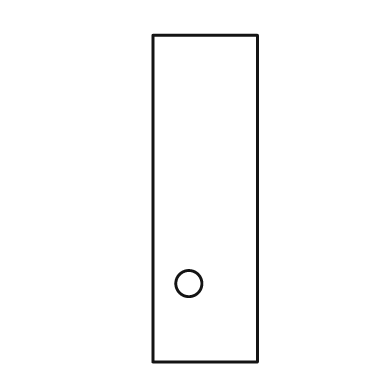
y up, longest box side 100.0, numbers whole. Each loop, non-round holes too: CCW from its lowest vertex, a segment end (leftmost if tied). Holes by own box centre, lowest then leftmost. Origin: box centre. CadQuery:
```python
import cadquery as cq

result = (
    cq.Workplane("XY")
    .moveTo(-16.0, -50.0)
    .lineTo(16.0, -50.0)
    .lineTo(16.0, 50.0)
    .lineTo(-16.0, 50.0)
    .close()
    .moveTo(-5.0, -26.0)
    .circle(4.0)
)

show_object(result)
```